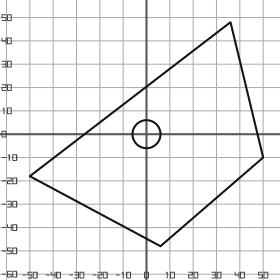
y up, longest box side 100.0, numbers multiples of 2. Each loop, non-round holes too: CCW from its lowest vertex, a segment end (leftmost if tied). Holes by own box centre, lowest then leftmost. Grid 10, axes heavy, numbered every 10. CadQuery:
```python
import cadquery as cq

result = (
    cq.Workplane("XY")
    .moveTo(6.0, -48.0)
    .lineTo(50.0, -10.0)
    .lineTo(36.0, 48.0)
    .lineTo(-50.0, -18.0)
    .close()
    .moveTo(0.0, 0.0)
    .circle(6.0)
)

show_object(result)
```